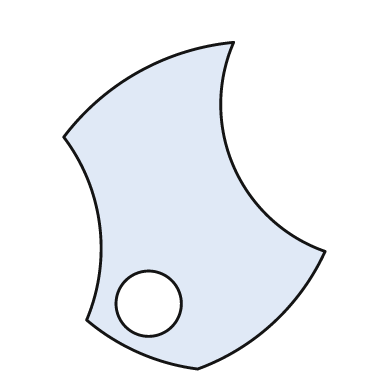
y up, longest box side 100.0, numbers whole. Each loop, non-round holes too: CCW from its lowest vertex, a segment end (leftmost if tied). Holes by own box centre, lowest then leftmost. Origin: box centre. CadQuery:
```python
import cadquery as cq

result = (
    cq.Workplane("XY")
    .moveTo(1.0, -50.0)
    .threePointArc((24.0, -36.0), (40.0, -14.0))
    .threePointArc((12.0, 12.0), (12.0, 50.0))
    .threePointArc((-17.0, 41.0), (-40.0, 21.0))
    .threePointArc((-29.0, -6.0), (-33.0, -35.0))
    .threePointArc((-17.0, -45.0), (1.0, -50.0))
    .close()
    .moveTo(-14.0, -30.0)
    .circle(10.0)
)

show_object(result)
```